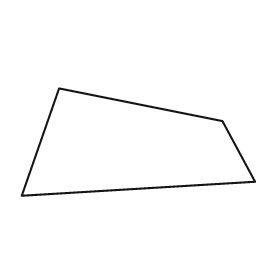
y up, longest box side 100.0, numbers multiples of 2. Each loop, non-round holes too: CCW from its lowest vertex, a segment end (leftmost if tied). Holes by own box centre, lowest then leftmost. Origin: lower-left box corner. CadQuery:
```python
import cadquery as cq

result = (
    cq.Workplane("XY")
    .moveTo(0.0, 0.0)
    .lineTo(100.0, 6.0)
    .lineTo(86.0, 32.0)
    .lineTo(16.0, 46.0)
    .close()
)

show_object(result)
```